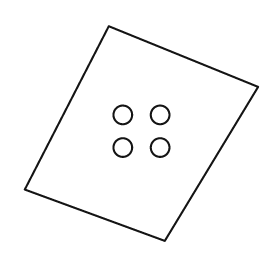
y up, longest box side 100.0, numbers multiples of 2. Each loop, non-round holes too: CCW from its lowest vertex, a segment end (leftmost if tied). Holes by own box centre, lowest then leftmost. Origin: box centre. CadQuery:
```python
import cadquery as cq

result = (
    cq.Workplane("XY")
    .moveTo(10.0, -46.0)
    .lineTo(50.0, 20.0)
    .lineTo(-14.0, 46.0)
    .lineTo(-50.0, -24.0)
    .close()
    .moveTo(-8.0, -6.0)
    .circle(4.0)
    .moveTo(8.0, -6.0)
    .circle(4.0)
    .moveTo(-8.0, 8.0)
    .circle(4.0)
    .moveTo(8.0, 8.0)
    .circle(4.0)
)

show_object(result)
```